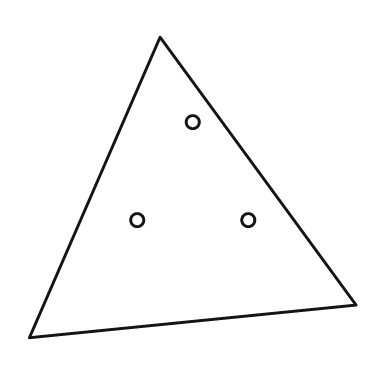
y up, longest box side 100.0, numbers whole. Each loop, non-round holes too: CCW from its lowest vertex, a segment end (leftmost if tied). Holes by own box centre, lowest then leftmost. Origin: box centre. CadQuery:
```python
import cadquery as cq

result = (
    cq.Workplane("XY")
    .moveTo(-50.0, -46.0)
    .lineTo(50.0, -36.0)
    .lineTo(-10.0, 46.0)
    .close()
    .moveTo(-17.0, -10.0)
    .circle(2.0)
    .moveTo(17.0, -10.0)
    .circle(2.0)
    .moveTo(0.0, 20.0)
    .circle(2.0)
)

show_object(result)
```